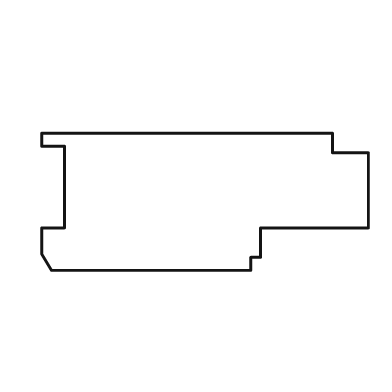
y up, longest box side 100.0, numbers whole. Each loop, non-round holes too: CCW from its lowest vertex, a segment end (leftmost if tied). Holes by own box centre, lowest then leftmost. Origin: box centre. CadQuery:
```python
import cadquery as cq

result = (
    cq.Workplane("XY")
    .moveTo(-47.0, -21.0)
    .lineTo(14.0, -21.0)
    .lineTo(14.0, -17.0)
    .lineTo(17.0, -17.0)
    .lineTo(17.0, -8.0)
    .lineTo(50.0, -8.0)
    .lineTo(50.0, 15.0)
    .lineTo(39.0, 15.0)
    .lineTo(39.0, 21.0)
    .lineTo(-50.0, 21.0)
    .lineTo(-50.0, 17.0)
    .lineTo(-43.0, 17.0)
    .lineTo(-43.0, -8.0)
    .lineTo(-50.0, -8.0)
    .lineTo(-50.0, -16.0)
    .close()
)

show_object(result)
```